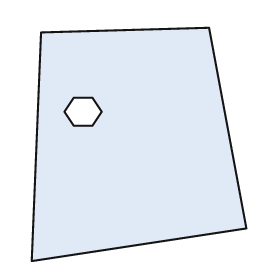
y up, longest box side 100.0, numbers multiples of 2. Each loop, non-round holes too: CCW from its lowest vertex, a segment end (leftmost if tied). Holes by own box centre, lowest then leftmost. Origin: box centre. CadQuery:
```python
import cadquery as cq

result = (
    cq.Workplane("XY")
    .moveTo(-46.0, -50.0)
    .lineTo(46.0, -36.0)
    .lineTo(30.0, 50.0)
    .lineTo(-42.0, 48.0)
    .close()
    .moveTo(-28.0, 8.0)
    .lineTo(-20.0, 8.0)
    .lineTo(-16.0, 14.0)
    .lineTo(-20.0, 20.0)
    .lineTo(-28.0, 20.0)
    .lineTo(-32.0, 14.0)
    .close()
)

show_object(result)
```